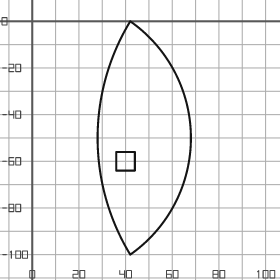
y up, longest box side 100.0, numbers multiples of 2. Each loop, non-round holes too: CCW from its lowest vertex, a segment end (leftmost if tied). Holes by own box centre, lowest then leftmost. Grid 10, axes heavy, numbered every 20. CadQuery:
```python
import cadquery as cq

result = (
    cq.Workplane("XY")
    .moveTo(42.0, -100.0)
    .threePointArc((68.0, -50.0), (42.0, 0.0))
    .threePointArc((28.0, -50.0), (42.0, -100.0))
    .close()
    .moveTo(36.0, -64.0)
    .lineTo(44.0, -64.0)
    .lineTo(44.0, -56.0)
    .lineTo(36.0, -56.0)
    .close()
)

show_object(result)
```